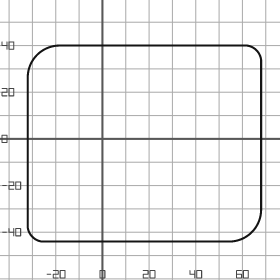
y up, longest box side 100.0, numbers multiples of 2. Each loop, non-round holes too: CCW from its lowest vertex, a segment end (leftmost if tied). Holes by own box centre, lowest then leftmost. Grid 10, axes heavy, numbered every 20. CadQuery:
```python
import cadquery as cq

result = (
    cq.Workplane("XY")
    .moveTo(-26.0, -44.0)
    .lineTo(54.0, -44.0)
    .threePointArc((64.0, -40.0), (68.0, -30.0))
    .lineTo(68.0, 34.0)
    .threePointArc((66.0, 38.0), (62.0, 40.0))
    .lineTo(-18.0, 40.0)
    .threePointArc((-28.0, 36.0), (-32.0, 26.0))
    .lineTo(-32.0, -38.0)
    .threePointArc((-30.0, -42.0), (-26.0, -44.0))
    .close()
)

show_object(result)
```